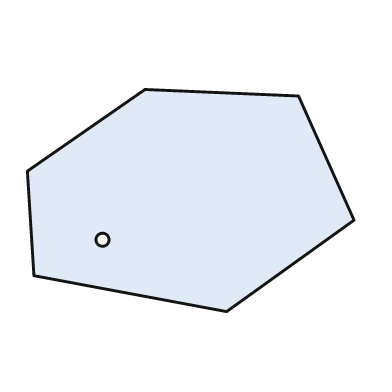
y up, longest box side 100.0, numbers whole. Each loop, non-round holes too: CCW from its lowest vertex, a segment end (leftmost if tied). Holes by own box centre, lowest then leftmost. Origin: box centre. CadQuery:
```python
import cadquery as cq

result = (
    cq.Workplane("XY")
    .moveTo(11.0, -34.0)
    .lineTo(50.0, -6.0)
    .lineTo(33.0, 32.0)
    .lineTo(-14.0, 34.0)
    .lineTo(-50.0, 9.0)
    .lineTo(-48.0, -23.0)
    .close()
    .moveTo(-27.0, -12.0)
    .circle(2.0)
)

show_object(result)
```